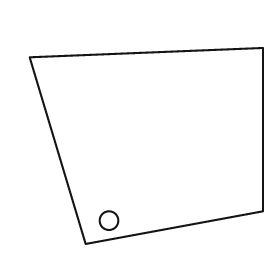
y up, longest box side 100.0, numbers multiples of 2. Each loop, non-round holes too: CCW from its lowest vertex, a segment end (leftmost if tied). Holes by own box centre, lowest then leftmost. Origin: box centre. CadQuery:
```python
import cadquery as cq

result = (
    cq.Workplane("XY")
    .moveTo(-26.0, -42.0)
    .lineTo(50.0, -28.0)
    .lineTo(50.0, 42.0)
    .lineTo(-50.0, 38.0)
    .close()
    .moveTo(-16.0, -32.0)
    .circle(4.0)
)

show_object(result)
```